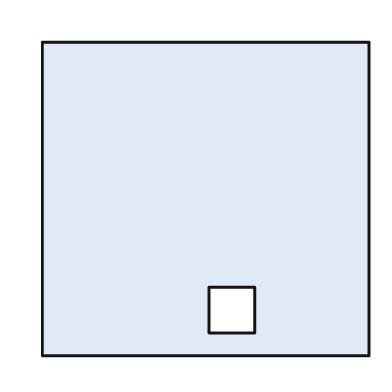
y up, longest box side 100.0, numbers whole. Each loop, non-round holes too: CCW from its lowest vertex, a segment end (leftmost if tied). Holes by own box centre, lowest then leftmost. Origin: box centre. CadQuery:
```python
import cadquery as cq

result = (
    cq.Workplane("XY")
    .moveTo(-50.0, -48.0)
    .lineTo(50.0, -48.0)
    .lineTo(50.0, 48.0)
    .lineTo(-50.0, 48.0)
    .close()
    .moveTo(1.0, -41.0)
    .lineTo(15.0, -41.0)
    .lineTo(15.0, -27.0)
    .lineTo(1.0, -27.0)
    .close()
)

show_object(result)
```